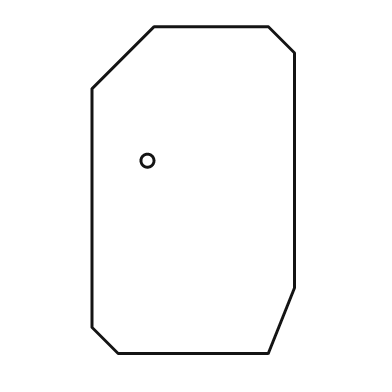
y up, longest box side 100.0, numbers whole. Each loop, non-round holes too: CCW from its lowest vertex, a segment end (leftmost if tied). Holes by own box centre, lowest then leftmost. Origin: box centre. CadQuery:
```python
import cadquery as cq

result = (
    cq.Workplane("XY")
    .moveTo(-23.0, -50.0)
    .lineTo(23.0, -50.0)
    .lineTo(31.0, -30.0)
    .lineTo(31.0, 42.0)
    .lineTo(23.0, 50.0)
    .lineTo(-12.0, 50.0)
    .lineTo(-31.0, 31.0)
    .lineTo(-31.0, -42.0)
    .close()
    .moveTo(-14.0, 9.0)
    .circle(2.0)
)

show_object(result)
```